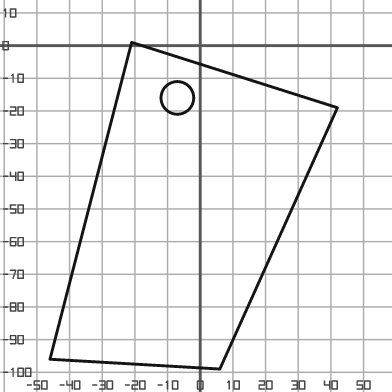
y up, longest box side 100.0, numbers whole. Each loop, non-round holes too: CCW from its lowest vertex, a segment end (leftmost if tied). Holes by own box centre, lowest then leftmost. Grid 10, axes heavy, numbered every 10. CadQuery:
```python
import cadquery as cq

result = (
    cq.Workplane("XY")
    .moveTo(6.0, -99.0)
    .lineTo(42.0, -19.0)
    .lineTo(-21.0, 1.0)
    .lineTo(-46.0, -96.0)
    .close()
    .moveTo(-7.0, -16.0)
    .circle(5.0)
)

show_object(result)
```